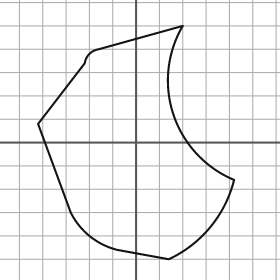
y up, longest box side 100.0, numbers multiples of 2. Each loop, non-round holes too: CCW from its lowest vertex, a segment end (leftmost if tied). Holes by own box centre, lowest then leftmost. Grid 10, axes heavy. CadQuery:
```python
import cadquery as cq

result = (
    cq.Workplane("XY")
    .moveTo(14.0, -50.0)
    .threePointArc((32.0, -36.0), (42.0, -16.0))
    .threePointArc((16.0, 12.0), (20.0, 50.0))
    .lineTo(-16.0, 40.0)
    .threePointArc((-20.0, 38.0), (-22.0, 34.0))
    .lineTo(-42.0, 8.0)
    .lineTo(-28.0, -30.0)
    .threePointArc((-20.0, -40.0), (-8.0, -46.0))
    .close()
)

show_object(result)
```